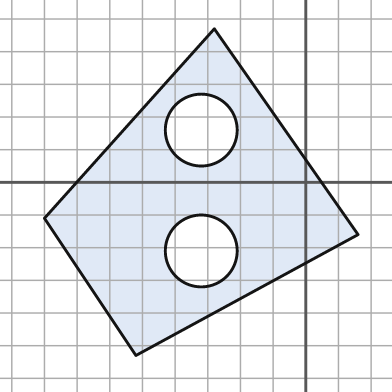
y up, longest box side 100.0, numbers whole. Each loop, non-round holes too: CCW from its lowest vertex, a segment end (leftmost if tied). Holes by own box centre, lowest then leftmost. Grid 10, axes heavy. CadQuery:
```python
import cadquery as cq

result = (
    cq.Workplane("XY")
    .moveTo(-52.0, -53.0)
    .lineTo(16.0, -16.0)
    .lineTo(-28.0, 47.0)
    .lineTo(-80.0, -11.0)
    .close()
    .moveTo(-32.0, -21.0)
    .circle(11.0)
    .moveTo(-32.0, 16.0)
    .circle(11.0)
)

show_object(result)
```